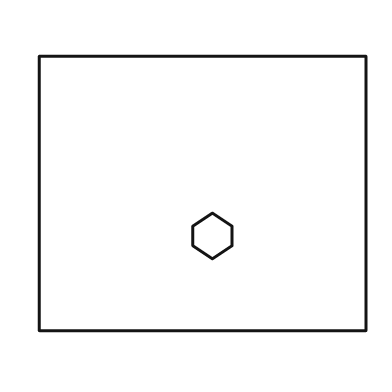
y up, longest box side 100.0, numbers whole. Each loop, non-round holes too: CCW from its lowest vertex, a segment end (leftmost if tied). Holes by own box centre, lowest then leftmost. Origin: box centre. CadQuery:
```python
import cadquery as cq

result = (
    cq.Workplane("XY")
    .moveTo(-50.0, -42.0)
    .lineTo(50.0, -42.0)
    .lineTo(50.0, 42.0)
    .lineTo(-50.0, 42.0)
    .close()
    .moveTo(3.0, -20.0)
    .lineTo(9.0, -16.0)
    .lineTo(9.0, -10.0)
    .lineTo(3.0, -6.0)
    .lineTo(-3.0, -10.0)
    .lineTo(-3.0, -16.0)
    .close()
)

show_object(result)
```